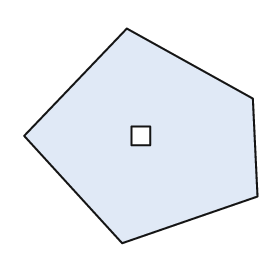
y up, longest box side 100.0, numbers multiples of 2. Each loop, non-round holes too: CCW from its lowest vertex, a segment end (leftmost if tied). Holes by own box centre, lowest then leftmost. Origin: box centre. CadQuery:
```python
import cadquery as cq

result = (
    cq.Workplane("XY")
    .moveTo(-8.0, -46.0)
    .lineTo(50.0, -26.0)
    .lineTo(48.0, 16.0)
    .lineTo(-6.0, 46.0)
    .lineTo(-50.0, 0.0)
    .close()
    .moveTo(-4.0, -4.0)
    .lineTo(4.0, -4.0)
    .lineTo(4.0, 4.0)
    .lineTo(-4.0, 4.0)
    .close()
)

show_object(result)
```